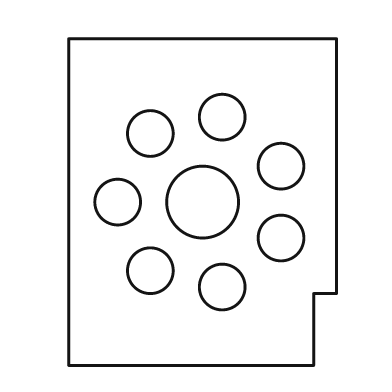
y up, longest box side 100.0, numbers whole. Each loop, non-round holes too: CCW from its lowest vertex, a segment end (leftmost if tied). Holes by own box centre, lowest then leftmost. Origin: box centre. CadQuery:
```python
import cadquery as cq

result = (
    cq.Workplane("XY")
    .moveTo(-41.0, -50.0)
    .lineTo(34.0, -50.0)
    .lineTo(34.0, -28.0)
    .lineTo(41.0, -28.0)
    .lineTo(41.0, 50.0)
    .lineTo(-41.0, 50.0)
    .close()
    .moveTo(6.0, -26.0)
    .circle(7.0)
    .moveTo(-16.0, -21.0)
    .circle(7.0)
    .moveTo(24.0, -11.0)
    .circle(7.0)
    .moveTo(-26.0, 0.0)
    .circle(7.0)
    .moveTo(0.0, 0.0)
    .circle(11.0)
    .moveTo(24.0, 11.0)
    .circle(7.0)
    .moveTo(-16.0, 21.0)
    .circle(7.0)
    .moveTo(6.0, 26.0)
    .circle(7.0)
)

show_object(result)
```